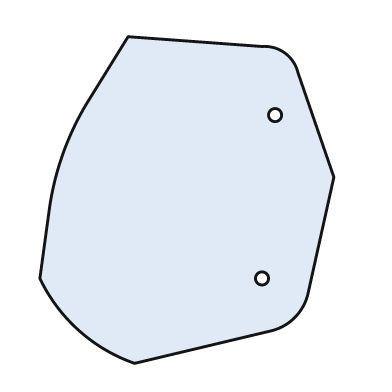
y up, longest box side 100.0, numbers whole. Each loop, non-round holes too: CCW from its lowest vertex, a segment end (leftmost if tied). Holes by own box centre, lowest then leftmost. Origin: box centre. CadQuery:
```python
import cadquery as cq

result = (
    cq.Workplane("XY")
    .moveTo(-16.0, -50.0)
    .lineTo(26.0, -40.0)
    .threePointArc((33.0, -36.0), (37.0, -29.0))
    .lineTo(45.0, 7.0)
    .lineTo(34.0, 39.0)
    .threePointArc((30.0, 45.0), (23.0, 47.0))
    .lineTo(-18.0, 50.0)
    .lineTo(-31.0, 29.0)
    .threePointArc((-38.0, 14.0), (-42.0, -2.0))
    .lineTo(-45.0, -24.0)
    .threePointArc((-33.0, -40.0), (-16.0, -50.0))
    .close()
    .moveTo(23.0, -24.0)
    .circle(2.0)
    .moveTo(27.0, 26.0)
    .circle(2.0)
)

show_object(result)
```